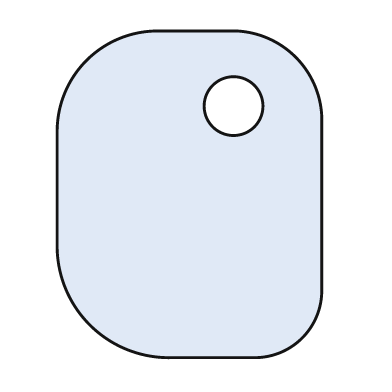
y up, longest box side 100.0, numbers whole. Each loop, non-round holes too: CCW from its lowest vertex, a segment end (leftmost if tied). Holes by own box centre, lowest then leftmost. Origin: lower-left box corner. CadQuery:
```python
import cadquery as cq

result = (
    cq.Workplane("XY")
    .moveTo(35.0, 0.0)
    .lineTo(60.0, 0.0)
    .threePointArc((75.0, 6.0), (81.0, 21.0))
    .lineTo(81.0, 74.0)
    .threePointArc((73.0, 92.0), (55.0, 100.0))
    .lineTo(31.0, 100.0)
    .threePointArc((9.0, 91.0), (0.0, 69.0))
    .lineTo(0.0, 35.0)
    .threePointArc((10.0, 10.0), (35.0, 0.0))
    .close()
    .moveTo(54.0, 77.0)
    .circle(9.0)
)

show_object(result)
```